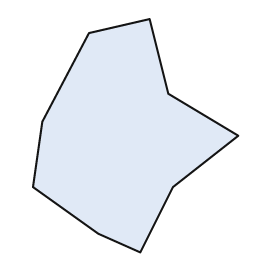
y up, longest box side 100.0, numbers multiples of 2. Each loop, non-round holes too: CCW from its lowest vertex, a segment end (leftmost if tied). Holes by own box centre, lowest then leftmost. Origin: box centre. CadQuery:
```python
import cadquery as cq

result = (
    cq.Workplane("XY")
    .moveTo(2.0, -50.0)
    .lineTo(16.0, -22.0)
    .lineTo(44.0, 0.0)
    .lineTo(14.0, 18.0)
    .lineTo(6.0, 50.0)
    .lineTo(-20.0, 44.0)
    .lineTo(-40.0, 6.0)
    .lineTo(-44.0, -22.0)
    .lineTo(-16.0, -42.0)
    .close()
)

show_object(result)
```